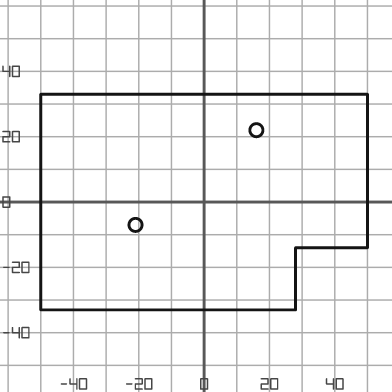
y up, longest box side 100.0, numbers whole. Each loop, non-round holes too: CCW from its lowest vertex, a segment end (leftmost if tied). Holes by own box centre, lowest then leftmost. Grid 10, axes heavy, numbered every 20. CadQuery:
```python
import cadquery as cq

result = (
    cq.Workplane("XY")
    .moveTo(-50.0, -33.0)
    .lineTo(28.0, -33.0)
    .lineTo(28.0, -14.0)
    .lineTo(50.0, -14.0)
    .lineTo(50.0, 33.0)
    .lineTo(-50.0, 33.0)
    .close()
    .moveTo(-21.0, -7.0)
    .circle(2.0)
    .moveTo(16.0, 22.0)
    .circle(2.0)
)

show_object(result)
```